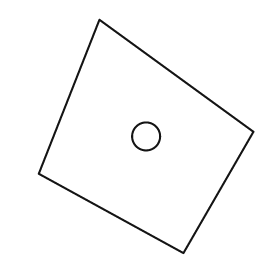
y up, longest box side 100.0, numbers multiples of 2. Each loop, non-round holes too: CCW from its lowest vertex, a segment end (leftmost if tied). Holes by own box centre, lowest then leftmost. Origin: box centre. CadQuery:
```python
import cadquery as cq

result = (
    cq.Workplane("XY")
    .moveTo(16.0, -50.0)
    .lineTo(46.0, 2.0)
    .lineTo(-20.0, 50.0)
    .lineTo(-46.0, -16.0)
    .close()
    .moveTo(0.0, 0.0)
    .circle(6.0)
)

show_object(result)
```